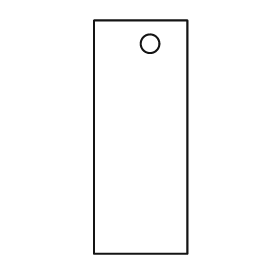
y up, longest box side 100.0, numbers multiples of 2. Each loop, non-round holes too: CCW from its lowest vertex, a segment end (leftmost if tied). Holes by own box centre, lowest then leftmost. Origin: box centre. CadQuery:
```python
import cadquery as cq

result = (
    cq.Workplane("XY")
    .moveTo(-20.0, -50.0)
    .lineTo(20.0, -50.0)
    .lineTo(20.0, 50.0)
    .lineTo(-20.0, 50.0)
    .close()
    .moveTo(4.0, 40.0)
    .circle(4.0)
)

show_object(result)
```